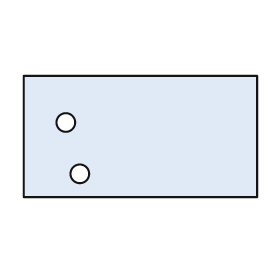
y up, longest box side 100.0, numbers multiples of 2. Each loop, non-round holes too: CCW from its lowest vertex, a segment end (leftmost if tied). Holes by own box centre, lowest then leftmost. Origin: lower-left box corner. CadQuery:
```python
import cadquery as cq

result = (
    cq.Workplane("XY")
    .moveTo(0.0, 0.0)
    .lineTo(100.0, 0.0)
    .lineTo(100.0, 52.0)
    .lineTo(0.0, 52.0)
    .close()
    .moveTo(24.0, 10.0)
    .circle(4.0)
    .moveTo(18.0, 32.0)
    .circle(4.0)
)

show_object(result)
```